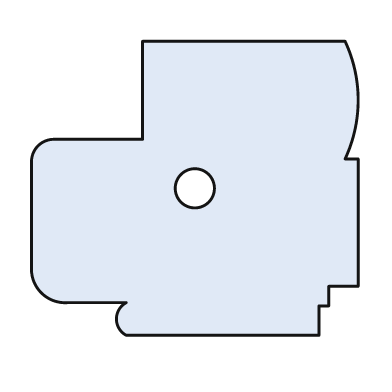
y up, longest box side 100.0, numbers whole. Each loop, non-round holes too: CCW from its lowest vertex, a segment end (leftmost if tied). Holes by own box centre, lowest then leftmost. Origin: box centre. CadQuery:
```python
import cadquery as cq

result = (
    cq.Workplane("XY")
    .moveTo(-21.0, -45.0)
    .lineTo(38.0, -45.0)
    .lineTo(38.0, -36.0)
    .lineTo(41.0, -36.0)
    .lineTo(41.0, -30.0)
    .lineTo(50.0, -30.0)
    .lineTo(50.0, 9.0)
    .lineTo(46.0, 9.0)
    .threePointArc((50.0, 27.0), (46.0, 45.0))
    .lineTo(-16.0, 45.0)
    .lineTo(-16.0, 15.0)
    .lineTo(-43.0, 15.0)
    .threePointArc((-48.0, 13.0), (-50.0, 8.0))
    .lineTo(-50.0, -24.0)
    .threePointArc((-47.0, -32.0), (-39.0, -35.0))
    .lineTo(-21.0, -35.0)
    .threePointArc((-24.0, -40.0), (-21.0, -45.0))
    .close()
    .moveTo(0.0, 0.0)
    .circle(6.0)
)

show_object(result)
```